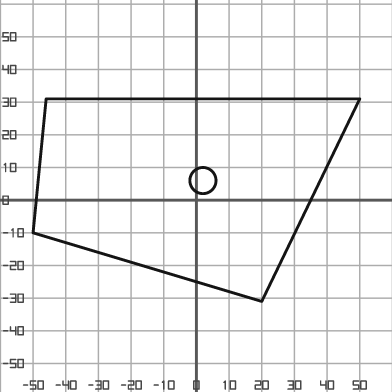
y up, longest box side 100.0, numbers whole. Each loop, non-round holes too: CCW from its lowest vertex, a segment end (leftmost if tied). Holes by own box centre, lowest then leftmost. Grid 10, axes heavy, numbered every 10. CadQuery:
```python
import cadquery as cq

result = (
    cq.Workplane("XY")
    .moveTo(20.0, -31.0)
    .lineTo(50.0, 31.0)
    .lineTo(-46.0, 31.0)
    .lineTo(-50.0, -10.0)
    .close()
    .moveTo(2.0, 6.0)
    .circle(4.0)
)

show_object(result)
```